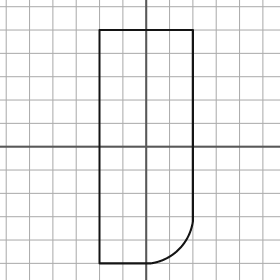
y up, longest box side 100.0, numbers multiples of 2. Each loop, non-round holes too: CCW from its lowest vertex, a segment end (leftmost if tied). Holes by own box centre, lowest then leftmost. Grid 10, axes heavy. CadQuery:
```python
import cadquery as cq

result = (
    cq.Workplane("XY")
    .moveTo(-20.0, -50.0)
    .lineTo(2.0, -50.0)
    .threePointArc((14.0, -44.0), (20.0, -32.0))
    .lineTo(20.0, 50.0)
    .lineTo(-20.0, 50.0)
    .close()
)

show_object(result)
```